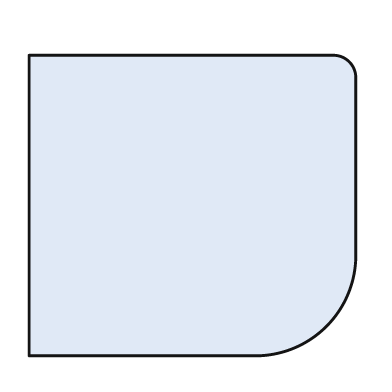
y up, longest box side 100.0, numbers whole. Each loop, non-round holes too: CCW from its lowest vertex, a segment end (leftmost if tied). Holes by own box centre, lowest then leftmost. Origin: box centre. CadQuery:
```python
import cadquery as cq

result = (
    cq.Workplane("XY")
    .moveTo(-50.0, -46.0)
    .lineTo(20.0, -46.0)
    .threePointArc((41.0, -37.0), (50.0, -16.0))
    .lineTo(50.0, 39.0)
    .threePointArc((48.0, 44.0), (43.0, 46.0))
    .lineTo(-50.0, 46.0)
    .close()
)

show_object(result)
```